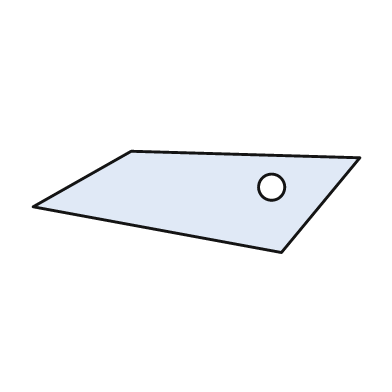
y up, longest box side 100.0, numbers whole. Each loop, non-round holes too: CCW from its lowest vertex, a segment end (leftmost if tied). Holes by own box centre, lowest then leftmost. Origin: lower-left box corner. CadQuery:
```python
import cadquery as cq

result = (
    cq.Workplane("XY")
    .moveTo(76.0, 0.0)
    .lineTo(100.0, 29.0)
    .lineTo(30.0, 31.0)
    .lineTo(0.0, 14.0)
    .close()
    .moveTo(73.0, 20.0)
    .circle(4.0)
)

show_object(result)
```